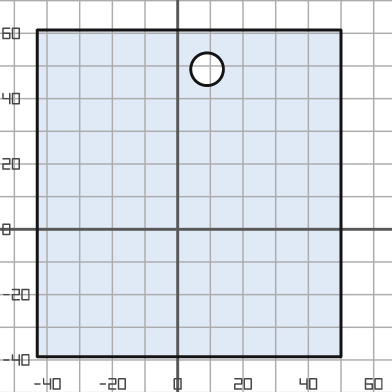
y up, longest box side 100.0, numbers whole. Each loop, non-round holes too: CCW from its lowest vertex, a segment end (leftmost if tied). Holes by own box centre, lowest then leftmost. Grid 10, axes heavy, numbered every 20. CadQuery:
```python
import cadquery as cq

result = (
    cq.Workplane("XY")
    .moveTo(-43.0, -39.0)
    .lineTo(50.0, -39.0)
    .lineTo(50.0, 61.0)
    .lineTo(-43.0, 61.0)
    .close()
    .moveTo(9.0, 49.0)
    .circle(5.0)
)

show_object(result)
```